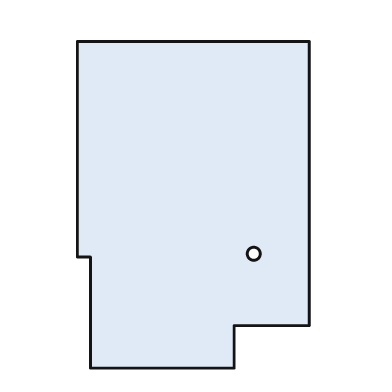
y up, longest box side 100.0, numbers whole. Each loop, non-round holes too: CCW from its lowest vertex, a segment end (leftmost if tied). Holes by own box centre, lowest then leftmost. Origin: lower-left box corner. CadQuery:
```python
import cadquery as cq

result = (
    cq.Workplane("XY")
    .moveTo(4.0, 0.0)
    .lineTo(48.0, 0.0)
    .lineTo(48.0, 13.0)
    .lineTo(71.0, 13.0)
    .lineTo(71.0, 100.0)
    .lineTo(0.0, 100.0)
    .lineTo(0.0, 34.0)
    .lineTo(4.0, 34.0)
    .close()
    .moveTo(54.0, 35.0)
    .circle(2.0)
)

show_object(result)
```